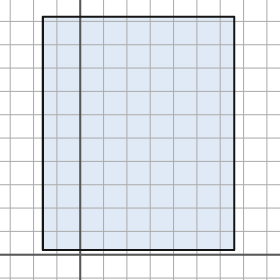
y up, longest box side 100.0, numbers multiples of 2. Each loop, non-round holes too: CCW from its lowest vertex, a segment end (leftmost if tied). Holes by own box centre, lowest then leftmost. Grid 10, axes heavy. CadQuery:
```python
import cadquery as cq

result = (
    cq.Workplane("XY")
    .moveTo(-16.0, 2.0)
    .lineTo(66.0, 2.0)
    .lineTo(66.0, 102.0)
    .lineTo(-16.0, 102.0)
    .close()
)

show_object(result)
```